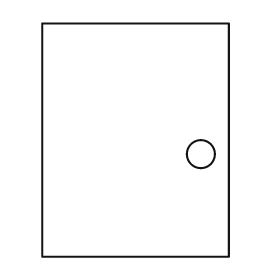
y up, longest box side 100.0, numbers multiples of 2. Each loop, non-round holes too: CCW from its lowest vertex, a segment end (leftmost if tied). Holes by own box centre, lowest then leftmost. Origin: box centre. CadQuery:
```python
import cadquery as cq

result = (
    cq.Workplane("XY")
    .moveTo(-40.0, -50.0)
    .lineTo(40.0, -50.0)
    .lineTo(40.0, 50.0)
    .lineTo(-40.0, 50.0)
    .close()
    .moveTo(28.0, -6.0)
    .circle(6.0)
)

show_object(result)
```